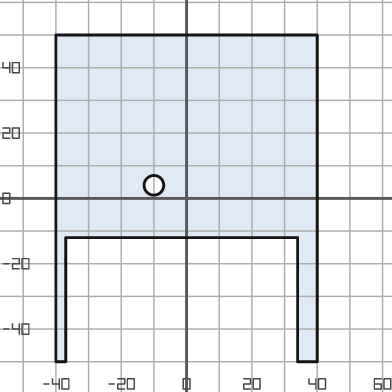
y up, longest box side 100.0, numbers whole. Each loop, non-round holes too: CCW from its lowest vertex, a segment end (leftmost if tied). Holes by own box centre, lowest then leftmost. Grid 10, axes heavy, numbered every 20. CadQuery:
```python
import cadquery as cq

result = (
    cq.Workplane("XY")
    .moveTo(-40.0, -50.0)
    .lineTo(-37.0, -50.0)
    .lineTo(-37.0, -12.0)
    .lineTo(34.0, -12.0)
    .lineTo(34.0, -50.0)
    .lineTo(40.0, -50.0)
    .lineTo(40.0, 50.0)
    .lineTo(-40.0, 50.0)
    .close()
    .moveTo(-10.0, 4.0)
    .circle(3.0)
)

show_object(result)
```